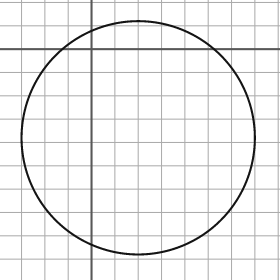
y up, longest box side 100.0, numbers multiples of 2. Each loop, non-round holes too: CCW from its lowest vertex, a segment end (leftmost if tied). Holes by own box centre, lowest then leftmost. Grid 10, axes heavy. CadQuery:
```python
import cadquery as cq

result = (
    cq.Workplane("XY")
    .moveTo(20.0, -38.0)
    .circle(50.0)
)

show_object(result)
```